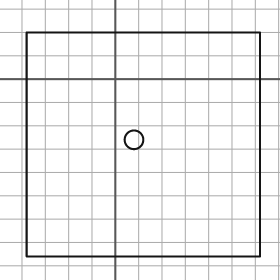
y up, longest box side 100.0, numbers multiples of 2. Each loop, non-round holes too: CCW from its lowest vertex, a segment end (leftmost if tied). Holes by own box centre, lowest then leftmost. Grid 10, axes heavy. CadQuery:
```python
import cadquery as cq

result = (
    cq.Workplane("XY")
    .moveTo(-38.0, -76.0)
    .lineTo(62.0, -76.0)
    .lineTo(62.0, 20.0)
    .lineTo(-38.0, 20.0)
    .close()
    .moveTo(8.0, -26.0)
    .circle(4.0)
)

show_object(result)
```